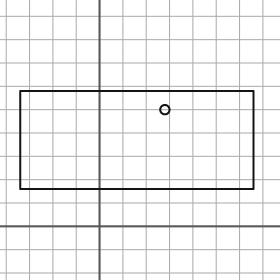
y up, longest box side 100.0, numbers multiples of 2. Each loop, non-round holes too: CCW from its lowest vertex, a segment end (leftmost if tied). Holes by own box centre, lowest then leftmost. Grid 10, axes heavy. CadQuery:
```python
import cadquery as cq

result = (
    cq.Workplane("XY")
    .moveTo(-34.0, 16.0)
    .lineTo(66.0, 16.0)
    .lineTo(66.0, 58.0)
    .lineTo(-34.0, 58.0)
    .close()
    .moveTo(28.0, 50.0)
    .circle(2.0)
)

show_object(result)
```